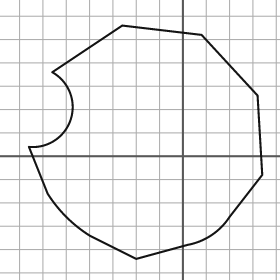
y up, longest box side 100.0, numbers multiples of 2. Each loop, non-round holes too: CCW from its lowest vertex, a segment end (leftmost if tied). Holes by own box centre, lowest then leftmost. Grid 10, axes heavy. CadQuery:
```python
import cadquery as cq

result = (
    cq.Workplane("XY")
    .moveTo(-20.0, -44.0)
    .lineTo(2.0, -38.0)
    .threePointArc((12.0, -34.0), (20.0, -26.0))
    .lineTo(34.0, -8.0)
    .lineTo(32.0, 26.0)
    .lineTo(8.0, 52.0)
    .lineTo(-26.0, 56.0)
    .lineTo(-56.0, 36.0)
    .threePointArc((-48.0, 16.0), (-66.0, 4.0))
    .lineTo(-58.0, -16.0)
    .threePointArc((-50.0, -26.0), (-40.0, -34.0))
    .close()
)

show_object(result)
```